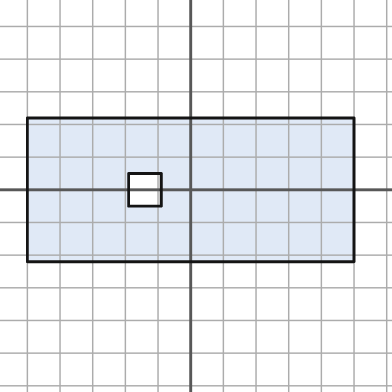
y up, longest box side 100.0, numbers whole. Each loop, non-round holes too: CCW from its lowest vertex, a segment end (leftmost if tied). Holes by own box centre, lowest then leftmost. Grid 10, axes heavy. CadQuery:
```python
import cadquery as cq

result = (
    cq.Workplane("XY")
    .moveTo(-50.0, -22.0)
    .lineTo(50.0, -22.0)
    .lineTo(50.0, 22.0)
    .lineTo(-50.0, 22.0)
    .close()
    .moveTo(-19.0, -5.0)
    .lineTo(-9.0, -5.0)
    .lineTo(-9.0, 5.0)
    .lineTo(-19.0, 5.0)
    .close()
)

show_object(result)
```